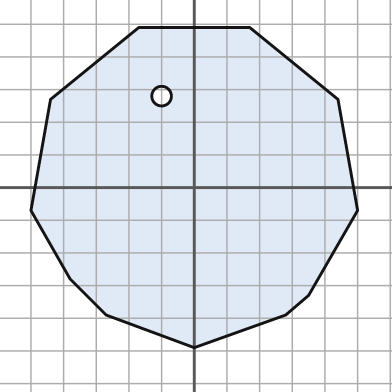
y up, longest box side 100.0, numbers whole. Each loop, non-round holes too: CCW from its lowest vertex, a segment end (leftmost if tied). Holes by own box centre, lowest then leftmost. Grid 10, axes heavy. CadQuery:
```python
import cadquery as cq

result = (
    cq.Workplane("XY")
    .moveTo(0.0, -49.0)
    .lineTo(28.0, -39.0)
    .lineTo(35.0, -33.0)
    .lineTo(50.0, -7.0)
    .lineTo(44.0, 27.0)
    .lineTo(17.0, 49.0)
    .lineTo(-17.0, 49.0)
    .lineTo(-44.0, 27.0)
    .lineTo(-50.0, -7.0)
    .lineTo(-38.0, -28.0)
    .lineTo(-27.0, -39.0)
    .close()
    .moveTo(-10.0, 28.0)
    .circle(3.0)
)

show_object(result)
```